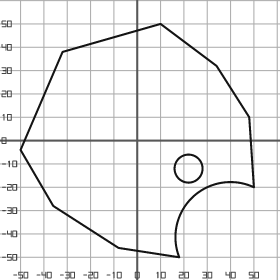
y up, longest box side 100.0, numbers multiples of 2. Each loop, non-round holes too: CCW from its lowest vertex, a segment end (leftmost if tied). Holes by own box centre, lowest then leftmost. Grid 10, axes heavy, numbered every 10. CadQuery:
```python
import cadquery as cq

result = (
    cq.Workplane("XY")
    .moveTo(18.0, -50.0)
    .threePointArc((24.0, -24.0), (50.0, -20.0))
    .lineTo(48.0, 10.0)
    .lineTo(34.0, 32.0)
    .lineTo(10.0, 50.0)
    .lineTo(-32.0, 38.0)
    .lineTo(-50.0, -4.0)
    .lineTo(-36.0, -28.0)
    .lineTo(-8.0, -46.0)
    .close()
    .moveTo(22.0, -12.0)
    .circle(6.0)
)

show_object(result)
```